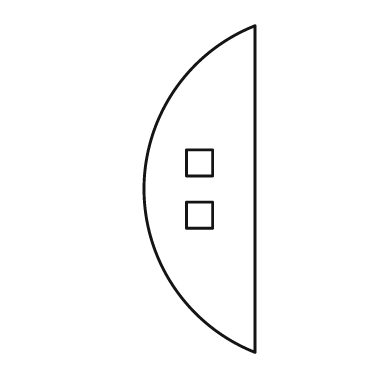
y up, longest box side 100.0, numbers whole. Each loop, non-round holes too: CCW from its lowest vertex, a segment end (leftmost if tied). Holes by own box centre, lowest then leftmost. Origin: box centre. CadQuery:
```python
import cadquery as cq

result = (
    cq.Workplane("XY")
    .moveTo(17.0, -50.0)
    .lineTo(17.0, 50.0)
    .threePointArc((-17.0, 0.0), (17.0, -50.0))
    .close()
    .moveTo(-4.0, -12.0)
    .lineTo(4.0, -12.0)
    .lineTo(4.0, -4.0)
    .lineTo(-4.0, -4.0)
    .close()
    .moveTo(-4.0, 4.0)
    .lineTo(4.0, 4.0)
    .lineTo(4.0, 12.0)
    .lineTo(-4.0, 12.0)
    .close()
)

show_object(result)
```